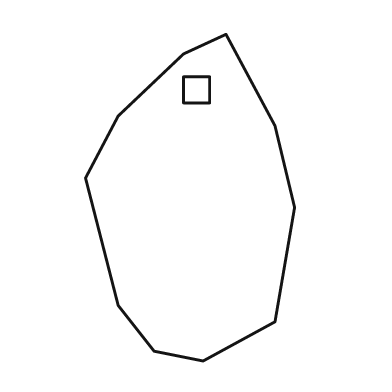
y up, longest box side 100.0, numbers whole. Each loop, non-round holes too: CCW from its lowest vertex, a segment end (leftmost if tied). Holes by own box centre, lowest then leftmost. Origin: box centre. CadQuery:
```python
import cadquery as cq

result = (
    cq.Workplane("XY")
    .moveTo(4.0, -50.0)
    .lineTo(26.0, -38.0)
    .lineTo(32.0, -3.0)
    .lineTo(26.0, 22.0)
    .lineTo(11.0, 50.0)
    .lineTo(-2.0, 44.0)
    .lineTo(-22.0, 25.0)
    .lineTo(-32.0, 6.0)
    .lineTo(-22.0, -33.0)
    .lineTo(-11.0, -47.0)
    .close()
    .moveTo(-2.0, 29.0)
    .lineTo(6.0, 29.0)
    .lineTo(6.0, 37.0)
    .lineTo(-2.0, 37.0)
    .close()
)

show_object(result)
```